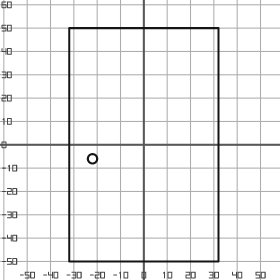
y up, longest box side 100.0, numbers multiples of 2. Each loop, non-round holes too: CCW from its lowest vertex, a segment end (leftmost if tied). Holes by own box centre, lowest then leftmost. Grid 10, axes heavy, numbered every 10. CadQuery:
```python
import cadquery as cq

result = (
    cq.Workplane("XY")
    .moveTo(-32.0, -50.0)
    .lineTo(32.0, -50.0)
    .lineTo(32.0, 50.0)
    .lineTo(-32.0, 50.0)
    .close()
    .moveTo(-22.0, -6.0)
    .circle(2.0)
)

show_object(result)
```